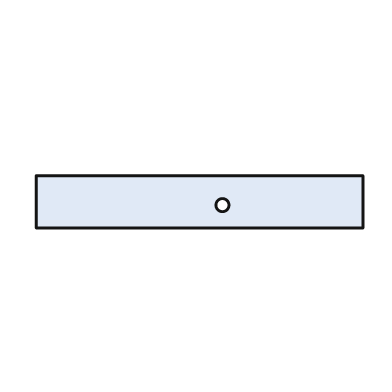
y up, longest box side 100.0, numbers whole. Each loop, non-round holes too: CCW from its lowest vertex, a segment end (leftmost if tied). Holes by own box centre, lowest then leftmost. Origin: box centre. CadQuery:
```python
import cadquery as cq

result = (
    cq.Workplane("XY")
    .moveTo(-50.0, -8.0)
    .lineTo(50.0, -8.0)
    .lineTo(50.0, 8.0)
    .lineTo(-50.0, 8.0)
    .close()
    .moveTo(7.0, -1.0)
    .circle(2.0)
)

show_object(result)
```